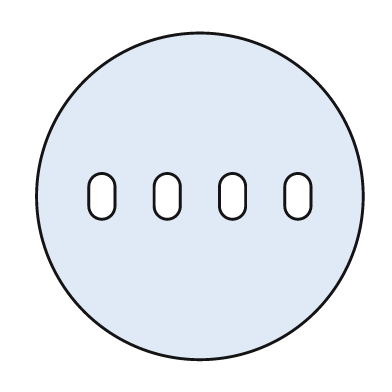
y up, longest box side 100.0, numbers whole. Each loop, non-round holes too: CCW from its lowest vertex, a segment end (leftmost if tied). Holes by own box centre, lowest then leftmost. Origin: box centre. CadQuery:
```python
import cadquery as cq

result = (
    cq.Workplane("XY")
    .moveTo(0.0, 0.0)
    .circle(50.0)
    .moveTo(-34.0, -3.0)
    .threePointArc((-30.0, -7.0), (-26.0, -3.0))
    .lineTo(-26.0, 3.0)
    .threePointArc((-30.0, 7.0), (-34.0, 3.0))
    .close()
    .moveTo(-14.0, -3.0)
    .threePointArc((-10.0, -7.0), (-6.0, -3.0))
    .lineTo(-6.0, 3.0)
    .threePointArc((-10.0, 7.0), (-14.0, 3.0))
    .close()
    .moveTo(6.0, -3.0)
    .threePointArc((10.0, -7.0), (14.0, -3.0))
    .lineTo(14.0, 3.0)
    .threePointArc((10.0, 7.0), (6.0, 3.0))
    .close()
    .moveTo(26.0, -3.0)
    .threePointArc((30.0, -7.0), (34.0, -3.0))
    .lineTo(34.0, 3.0)
    .threePointArc((30.0, 7.0), (26.0, 3.0))
    .close()
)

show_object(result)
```